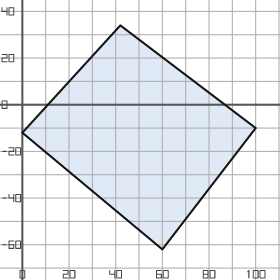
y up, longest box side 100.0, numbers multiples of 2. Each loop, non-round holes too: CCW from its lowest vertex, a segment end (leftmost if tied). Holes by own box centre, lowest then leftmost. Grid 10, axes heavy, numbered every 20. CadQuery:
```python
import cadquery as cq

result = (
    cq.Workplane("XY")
    .moveTo(60.0, -62.0)
    .lineTo(100.0, -10.0)
    .lineTo(42.0, 34.0)
    .lineTo(0.0, -12.0)
    .close()
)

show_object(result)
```